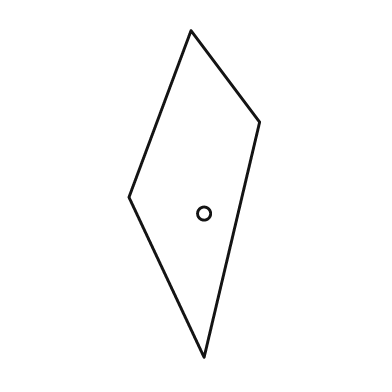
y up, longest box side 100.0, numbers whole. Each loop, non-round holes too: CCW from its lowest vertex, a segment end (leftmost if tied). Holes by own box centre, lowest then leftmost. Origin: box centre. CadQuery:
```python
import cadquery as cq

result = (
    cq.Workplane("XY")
    .moveTo(3.0, -50.0)
    .lineTo(20.0, 22.0)
    .lineTo(-1.0, 50.0)
    .lineTo(-20.0, -1.0)
    .close()
    .moveTo(3.0, -6.0)
    .circle(2.0)
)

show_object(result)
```